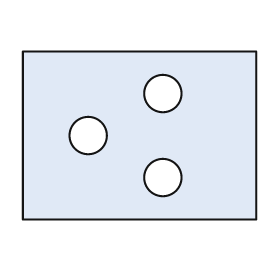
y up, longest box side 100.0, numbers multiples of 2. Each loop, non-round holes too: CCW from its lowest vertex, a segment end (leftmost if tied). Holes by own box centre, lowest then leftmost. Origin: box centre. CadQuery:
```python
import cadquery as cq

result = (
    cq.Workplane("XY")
    .moveTo(-50.0, -36.0)
    .lineTo(50.0, -36.0)
    .lineTo(50.0, 36.0)
    .lineTo(-50.0, 36.0)
    .close()
    .moveTo(10.0, -18.0)
    .circle(8.0)
    .moveTo(-22.0, 0.0)
    .circle(8.0)
    .moveTo(10.0, 18.0)
    .circle(8.0)
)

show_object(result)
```